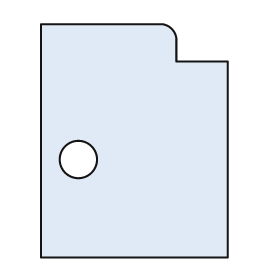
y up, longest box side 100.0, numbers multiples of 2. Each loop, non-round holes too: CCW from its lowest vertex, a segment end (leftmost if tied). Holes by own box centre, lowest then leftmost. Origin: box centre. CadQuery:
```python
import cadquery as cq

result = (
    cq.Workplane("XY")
    .moveTo(-40.0, -50.0)
    .lineTo(40.0, -50.0)
    .lineTo(40.0, 34.0)
    .lineTo(18.0, 34.0)
    .lineTo(18.0, 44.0)
    .threePointArc((16.0, 48.0), (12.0, 50.0))
    .lineTo(-40.0, 50.0)
    .close()
    .moveTo(-24.0, -8.0)
    .circle(8.0)
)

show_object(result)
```